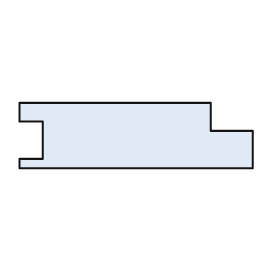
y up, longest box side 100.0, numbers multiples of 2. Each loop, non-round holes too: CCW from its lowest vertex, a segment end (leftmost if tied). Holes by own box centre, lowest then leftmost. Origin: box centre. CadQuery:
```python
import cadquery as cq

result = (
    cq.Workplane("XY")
    .moveTo(-50.0, -14.0)
    .lineTo(50.0, -14.0)
    .lineTo(50.0, 2.0)
    .lineTo(32.0, 2.0)
    .lineTo(32.0, 14.0)
    .lineTo(-50.0, 14.0)
    .lineTo(-50.0, 6.0)
    .lineTo(-40.0, 6.0)
    .lineTo(-40.0, -10.0)
    .lineTo(-50.0, -10.0)
    .close()
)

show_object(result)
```